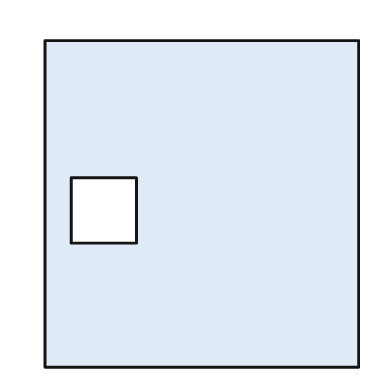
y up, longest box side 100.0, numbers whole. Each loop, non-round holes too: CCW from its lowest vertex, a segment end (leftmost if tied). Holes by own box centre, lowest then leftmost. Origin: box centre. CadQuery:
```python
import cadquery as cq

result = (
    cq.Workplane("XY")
    .moveTo(-48.0, -50.0)
    .lineTo(48.0, -50.0)
    .lineTo(48.0, 50.0)
    .lineTo(-48.0, 50.0)
    .close()
    .moveTo(-40.0, -12.0)
    .lineTo(-20.0, -12.0)
    .lineTo(-20.0, 8.0)
    .lineTo(-40.0, 8.0)
    .close()
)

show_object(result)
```